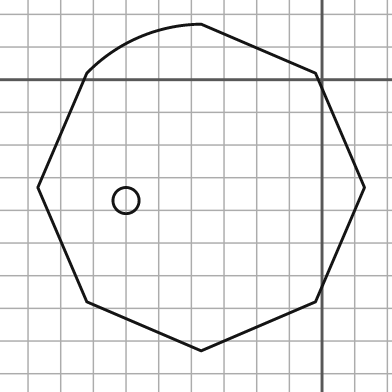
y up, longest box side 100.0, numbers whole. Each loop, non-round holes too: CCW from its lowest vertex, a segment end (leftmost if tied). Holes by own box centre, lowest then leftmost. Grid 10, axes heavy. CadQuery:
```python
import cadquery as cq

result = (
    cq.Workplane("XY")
    .moveTo(-37.0, -83.0)
    .lineTo(-2.0, -68.0)
    .lineTo(13.0, -33.0)
    .lineTo(-2.0, 2.0)
    .lineTo(-37.0, 17.0)
    .threePointArc((-56.0, 13.0), (-72.0, 2.0))
    .lineTo(-87.0, -33.0)
    .lineTo(-72.0, -68.0)
    .close()
    .moveTo(-60.0, -37.0)
    .circle(4.0)
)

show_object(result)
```